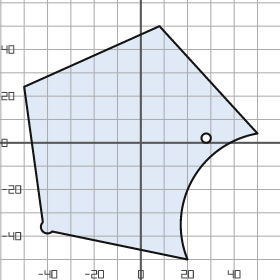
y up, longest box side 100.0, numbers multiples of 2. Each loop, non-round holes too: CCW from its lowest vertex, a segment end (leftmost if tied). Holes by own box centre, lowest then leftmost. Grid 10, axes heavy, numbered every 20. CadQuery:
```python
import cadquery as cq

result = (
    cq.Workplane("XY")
    .moveTo(20.0, -50.0)
    .threePointArc((22.0, -16.0), (50.0, 4.0))
    .lineTo(8.0, 50.0)
    .lineTo(-50.0, 24.0)
    .lineTo(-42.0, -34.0)
    .threePointArc((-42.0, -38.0), (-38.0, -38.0))
    .close()
    .moveTo(28.0, 2.0)
    .circle(2.0)
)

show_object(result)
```